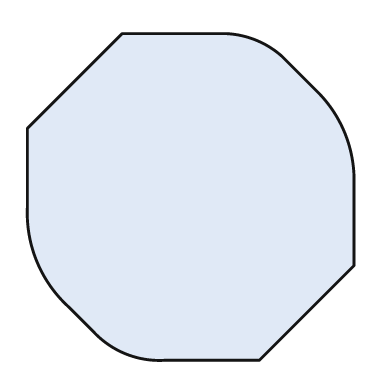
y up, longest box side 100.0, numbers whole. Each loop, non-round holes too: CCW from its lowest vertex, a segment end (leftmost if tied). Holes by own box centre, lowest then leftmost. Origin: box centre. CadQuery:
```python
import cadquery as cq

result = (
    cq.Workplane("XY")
    .moveTo(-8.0, -50.0)
    .lineTo(21.0, -50.0)
    .lineTo(50.0, -21.0)
    .lineTo(50.0, 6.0)
    .threePointArc((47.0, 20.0), (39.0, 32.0))
    .lineTo(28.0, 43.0)
    .threePointArc((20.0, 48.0), (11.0, 50.0))
    .lineTo(-21.0, 50.0)
    .lineTo(-50.0, 21.0)
    .lineTo(-50.0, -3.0)
    .threePointArc((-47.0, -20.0), (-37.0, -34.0))
    .lineTo(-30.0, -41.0)
    .threePointArc((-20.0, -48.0), (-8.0, -50.0))
    .close()
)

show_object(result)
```